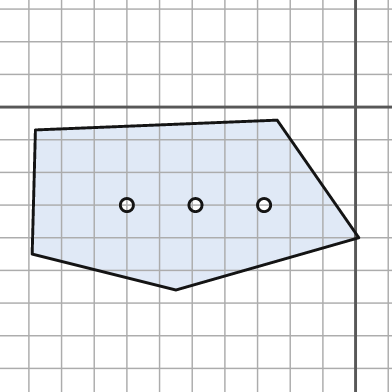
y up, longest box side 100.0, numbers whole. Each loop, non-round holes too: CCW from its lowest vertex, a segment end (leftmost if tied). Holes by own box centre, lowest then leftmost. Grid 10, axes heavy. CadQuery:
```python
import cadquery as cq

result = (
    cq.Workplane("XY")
    .moveTo(-55.0, -56.0)
    .lineTo(1.0, -40.0)
    .lineTo(-24.0, -4.0)
    .lineTo(-98.0, -7.0)
    .lineTo(-99.0, -45.0)
    .close()
    .moveTo(-70.0, -30.0)
    .circle(2.0)
    .moveTo(-49.0, -30.0)
    .circle(2.0)
    .moveTo(-28.0, -30.0)
    .circle(2.0)
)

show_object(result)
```